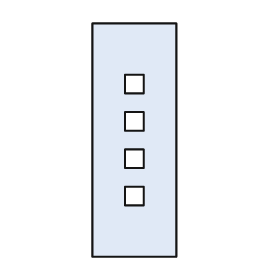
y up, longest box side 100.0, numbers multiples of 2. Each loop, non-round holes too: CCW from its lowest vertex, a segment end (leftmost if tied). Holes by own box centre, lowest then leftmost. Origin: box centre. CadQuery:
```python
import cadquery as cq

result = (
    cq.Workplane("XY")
    .moveTo(-18.0, -50.0)
    .lineTo(18.0, -50.0)
    .lineTo(18.0, 50.0)
    .lineTo(-18.0, 50.0)
    .close()
    .moveTo(-4.0, -28.0)
    .lineTo(4.0, -28.0)
    .lineTo(4.0, -20.0)
    .lineTo(-4.0, -20.0)
    .close()
    .moveTo(-4.0, -12.0)
    .lineTo(4.0, -12.0)
    .lineTo(4.0, -4.0)
    .lineTo(-4.0, -4.0)
    .close()
    .moveTo(-4.0, 4.0)
    .lineTo(4.0, 4.0)
    .lineTo(4.0, 12.0)
    .lineTo(-4.0, 12.0)
    .close()
    .moveTo(-4.0, 20.0)
    .lineTo(4.0, 20.0)
    .lineTo(4.0, 28.0)
    .lineTo(-4.0, 28.0)
    .close()
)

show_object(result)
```